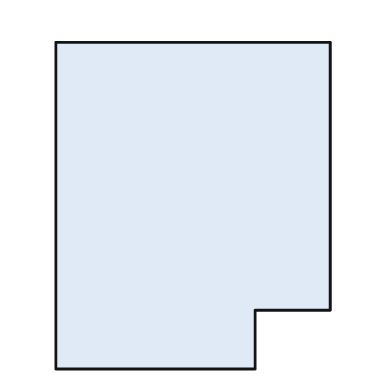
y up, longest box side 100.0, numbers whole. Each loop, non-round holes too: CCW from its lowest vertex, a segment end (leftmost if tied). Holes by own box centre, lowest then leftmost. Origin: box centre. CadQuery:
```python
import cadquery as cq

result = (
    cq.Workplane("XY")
    .moveTo(-42.0, -50.0)
    .lineTo(19.0, -50.0)
    .lineTo(19.0, -32.0)
    .lineTo(42.0, -32.0)
    .lineTo(42.0, 50.0)
    .lineTo(-42.0, 50.0)
    .close()
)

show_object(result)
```